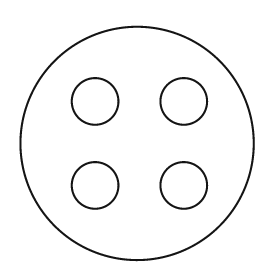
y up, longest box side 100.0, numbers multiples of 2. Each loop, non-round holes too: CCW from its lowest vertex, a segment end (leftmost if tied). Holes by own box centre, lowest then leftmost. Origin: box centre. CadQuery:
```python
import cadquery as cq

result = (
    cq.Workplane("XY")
    .moveTo(0.0, 0.0)
    .circle(50.0)
    .moveTo(-18.0, -18.0)
    .circle(10.0)
    .moveTo(20.0, -18.0)
    .circle(10.0)
    .moveTo(-18.0, 18.0)
    .circle(10.0)
    .moveTo(20.0, 18.0)
    .circle(10.0)
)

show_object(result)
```